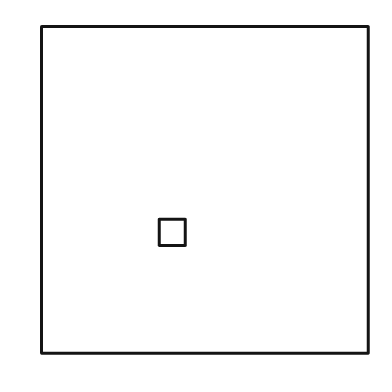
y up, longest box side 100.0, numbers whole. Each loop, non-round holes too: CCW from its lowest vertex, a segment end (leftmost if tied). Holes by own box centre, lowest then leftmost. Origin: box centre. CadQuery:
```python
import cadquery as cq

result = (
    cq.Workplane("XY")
    .moveTo(-50.0, -50.0)
    .lineTo(50.0, -50.0)
    .lineTo(50.0, 50.0)
    .lineTo(-50.0, 50.0)
    .close()
    .moveTo(-14.0, -17.0)
    .lineTo(-6.0, -17.0)
    .lineTo(-6.0, -9.0)
    .lineTo(-14.0, -9.0)
    .close()
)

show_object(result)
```